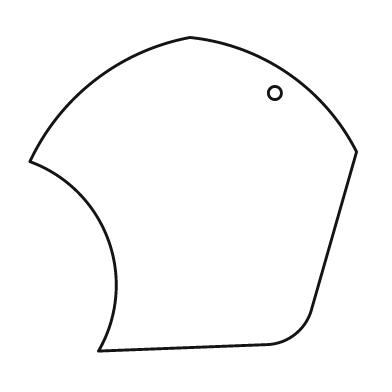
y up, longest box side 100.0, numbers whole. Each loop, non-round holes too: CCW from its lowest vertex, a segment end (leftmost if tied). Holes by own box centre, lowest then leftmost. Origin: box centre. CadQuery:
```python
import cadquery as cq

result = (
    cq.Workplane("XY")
    .moveTo(-29.0, -48.0)
    .lineTo(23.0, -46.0)
    .threePointArc((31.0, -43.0), (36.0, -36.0))
    .lineTo(50.0, 13.0)
    .threePointArc((29.0, 37.0), (-1.0, 48.0))
    .threePointArc((-30.0, 35.0), (-50.0, 10.0))
    .threePointArc((-26.0, -14.0), (-29.0, -48.0))
    .close()
    .moveTo(25.0, 31.0)
    .circle(2.0)
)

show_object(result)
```